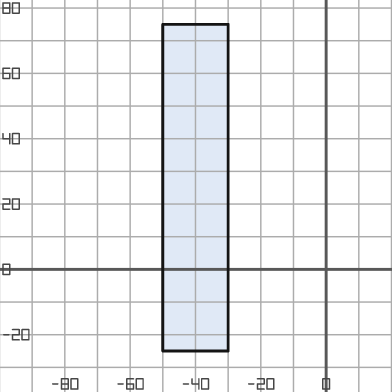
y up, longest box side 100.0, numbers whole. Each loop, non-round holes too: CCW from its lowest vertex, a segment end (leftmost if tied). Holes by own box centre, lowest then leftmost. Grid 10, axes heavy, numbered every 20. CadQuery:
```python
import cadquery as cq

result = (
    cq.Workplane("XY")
    .moveTo(-50.0, -25.0)
    .lineTo(-30.0, -25.0)
    .lineTo(-30.0, 75.0)
    .lineTo(-50.0, 75.0)
    .close()
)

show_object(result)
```